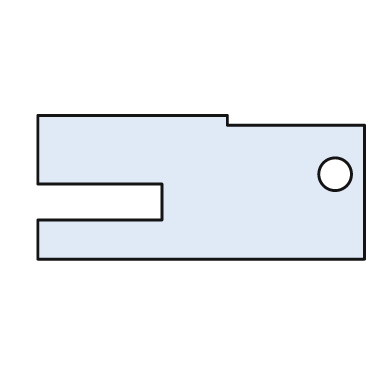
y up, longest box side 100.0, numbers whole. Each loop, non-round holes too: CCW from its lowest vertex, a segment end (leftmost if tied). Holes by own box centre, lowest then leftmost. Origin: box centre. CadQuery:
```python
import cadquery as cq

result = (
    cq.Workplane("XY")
    .moveTo(-50.0, -22.0)
    .lineTo(50.0, -22.0)
    .lineTo(50.0, 19.0)
    .lineTo(8.0, 19.0)
    .lineTo(8.0, 22.0)
    .lineTo(-50.0, 22.0)
    .lineTo(-50.0, 1.0)
    .lineTo(-12.0, 1.0)
    .lineTo(-12.0, -10.0)
    .lineTo(-50.0, -10.0)
    .close()
    .moveTo(41.0, 4.0)
    .circle(5.0)
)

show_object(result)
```